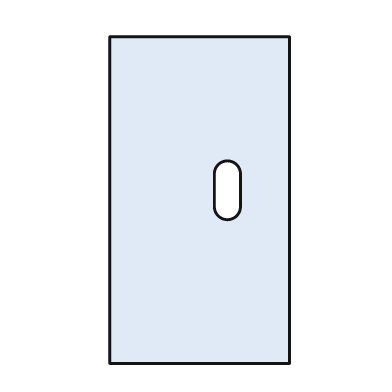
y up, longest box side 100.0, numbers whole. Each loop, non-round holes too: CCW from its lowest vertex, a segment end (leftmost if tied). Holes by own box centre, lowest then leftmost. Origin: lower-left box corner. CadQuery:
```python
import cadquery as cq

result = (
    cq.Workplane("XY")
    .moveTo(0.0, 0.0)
    .lineTo(55.0, 0.0)
    .lineTo(55.0, 100.0)
    .lineTo(0.0, 100.0)
    .close()
    .moveTo(32.0, 48.0)
    .threePointArc((36.0, 44.0), (40.0, 48.0))
    .lineTo(40.0, 58.0)
    .threePointArc((36.0, 62.0), (32.0, 58.0))
    .close()
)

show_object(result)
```